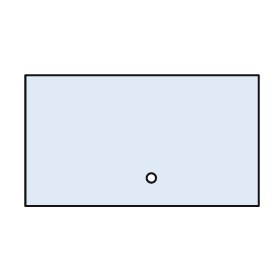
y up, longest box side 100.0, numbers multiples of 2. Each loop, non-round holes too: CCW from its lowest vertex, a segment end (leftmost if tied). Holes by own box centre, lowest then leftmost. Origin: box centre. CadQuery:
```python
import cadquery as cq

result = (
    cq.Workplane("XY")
    .moveTo(-50.0, -28.0)
    .lineTo(50.0, -28.0)
    .lineTo(50.0, 28.0)
    .lineTo(-50.0, 28.0)
    .close()
    .moveTo(4.0, -16.0)
    .circle(2.0)
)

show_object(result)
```